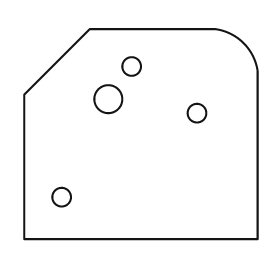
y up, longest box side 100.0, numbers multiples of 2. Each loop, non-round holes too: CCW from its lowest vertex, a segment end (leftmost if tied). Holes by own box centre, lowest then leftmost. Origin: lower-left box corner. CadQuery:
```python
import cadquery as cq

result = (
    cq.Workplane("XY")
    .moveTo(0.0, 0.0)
    .lineTo(100.0, 0.0)
    .lineTo(100.0, 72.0)
    .threePointArc((94.0, 84.0), (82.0, 90.0))
    .lineTo(28.0, 90.0)
    .lineTo(0.0, 62.0)
    .close()
    .moveTo(16.0, 18.0)
    .circle(4.0)
    .moveTo(74.0, 54.0)
    .circle(4.0)
    .moveTo(36.0, 60.0)
    .circle(6.0)
    .moveTo(46.0, 74.0)
    .circle(4.0)
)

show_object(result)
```